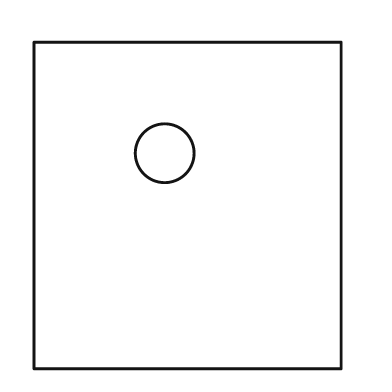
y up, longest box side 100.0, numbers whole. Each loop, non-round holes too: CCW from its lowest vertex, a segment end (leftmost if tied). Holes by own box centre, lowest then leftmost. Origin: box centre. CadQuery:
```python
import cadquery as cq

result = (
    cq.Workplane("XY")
    .moveTo(-47.0, -50.0)
    .lineTo(47.0, -50.0)
    .lineTo(47.0, 50.0)
    .lineTo(-47.0, 50.0)
    .close()
    .moveTo(-7.0, 16.0)
    .circle(9.0)
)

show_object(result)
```